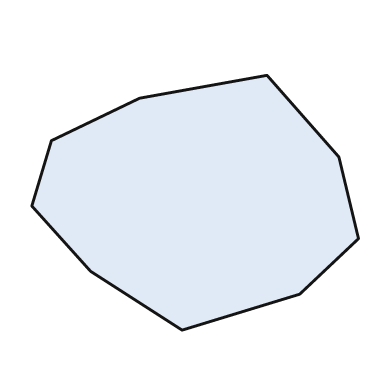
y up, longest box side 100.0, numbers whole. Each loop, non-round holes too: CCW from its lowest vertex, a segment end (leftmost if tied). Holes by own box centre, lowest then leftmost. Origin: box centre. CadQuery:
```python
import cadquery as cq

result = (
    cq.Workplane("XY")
    .moveTo(-4.0, -39.0)
    .lineTo(32.0, -28.0)
    .lineTo(50.0, -11.0)
    .lineTo(44.0, 14.0)
    .lineTo(22.0, 39.0)
    .lineTo(-17.0, 32.0)
    .lineTo(-44.0, 19.0)
    .lineTo(-50.0, -1.0)
    .lineTo(-32.0, -21.0)
    .close()
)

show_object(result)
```